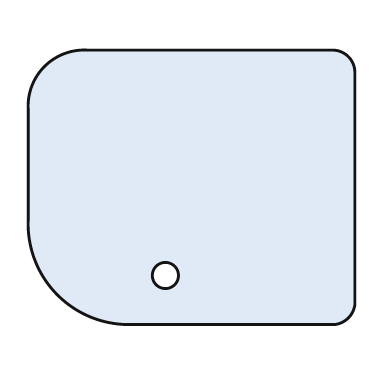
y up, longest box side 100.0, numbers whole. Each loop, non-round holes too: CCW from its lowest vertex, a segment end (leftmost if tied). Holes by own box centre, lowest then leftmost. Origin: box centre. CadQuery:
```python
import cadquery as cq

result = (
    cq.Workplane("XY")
    .moveTo(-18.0, -42.0)
    .lineTo(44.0, -42.0)
    .threePointArc((48.0, -40.0), (50.0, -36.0))
    .lineTo(50.0, 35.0)
    .threePointArc((48.0, 40.0), (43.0, 42.0))
    .lineTo(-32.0, 42.0)
    .threePointArc((-45.0, 37.0), (-50.0, 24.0))
    .lineTo(-50.0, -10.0)
    .threePointArc((-41.0, -33.0), (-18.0, -42.0))
    .close()
    .moveTo(-8.0, -27.0)
    .circle(4.0)
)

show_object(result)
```